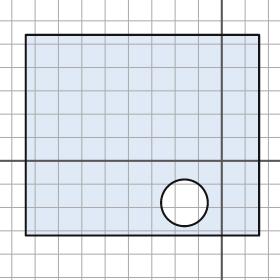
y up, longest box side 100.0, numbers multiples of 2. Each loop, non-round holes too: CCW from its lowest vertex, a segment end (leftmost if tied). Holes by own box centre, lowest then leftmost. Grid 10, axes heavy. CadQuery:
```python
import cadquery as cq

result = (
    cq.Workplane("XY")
    .moveTo(-84.0, -32.0)
    .lineTo(16.0, -32.0)
    .lineTo(16.0, 54.0)
    .lineTo(-84.0, 54.0)
    .close()
    .moveTo(-16.0, -18.0)
    .circle(10.0)
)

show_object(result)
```